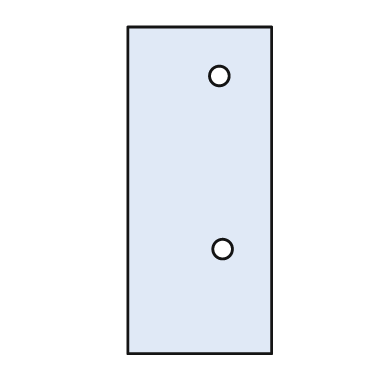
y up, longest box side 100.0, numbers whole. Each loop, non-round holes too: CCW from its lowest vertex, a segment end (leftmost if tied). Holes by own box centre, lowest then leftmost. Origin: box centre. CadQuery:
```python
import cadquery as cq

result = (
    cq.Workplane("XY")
    .moveTo(-22.0, -50.0)
    .lineTo(22.0, -50.0)
    .lineTo(22.0, 50.0)
    .lineTo(-22.0, 50.0)
    .close()
    .moveTo(7.0, -18.0)
    .circle(3.0)
    .moveTo(6.0, 35.0)
    .circle(3.0)
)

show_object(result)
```